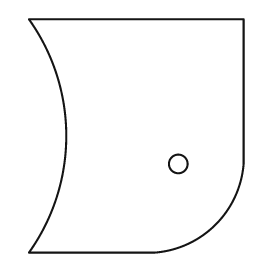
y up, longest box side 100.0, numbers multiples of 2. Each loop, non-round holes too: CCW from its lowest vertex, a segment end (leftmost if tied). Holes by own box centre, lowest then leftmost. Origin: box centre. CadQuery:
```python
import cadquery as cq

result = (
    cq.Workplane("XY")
    .moveTo(-46.0, -50.0)
    .lineTo(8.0, -50.0)
    .threePointArc((34.0, -38.0), (46.0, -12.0))
    .lineTo(46.0, 50.0)
    .lineTo(-46.0, 50.0)
    .threePointArc((-30.0, 0.0), (-46.0, -50.0))
    .close()
    .moveTo(18.0, -12.0)
    .circle(4.0)
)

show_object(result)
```